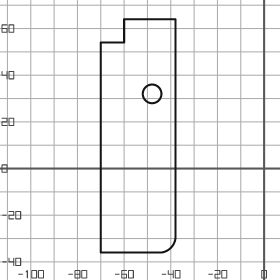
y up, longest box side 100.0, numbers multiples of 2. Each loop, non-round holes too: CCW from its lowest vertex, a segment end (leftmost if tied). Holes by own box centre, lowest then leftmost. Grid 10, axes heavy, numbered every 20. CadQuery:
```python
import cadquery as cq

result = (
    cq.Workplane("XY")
    .moveTo(-70.0, -36.0)
    .lineTo(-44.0, -36.0)
    .threePointArc((-40.0, -34.0), (-38.0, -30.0))
    .lineTo(-38.0, 64.0)
    .lineTo(-60.0, 64.0)
    .lineTo(-60.0, 54.0)
    .lineTo(-70.0, 54.0)
    .close()
    .moveTo(-48.0, 32.0)
    .circle(4.0)
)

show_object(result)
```